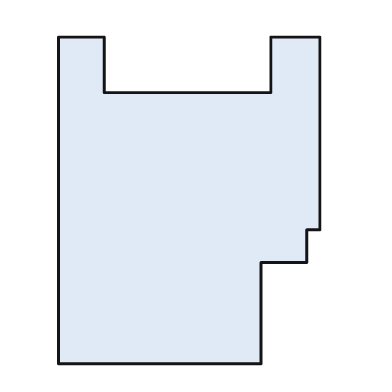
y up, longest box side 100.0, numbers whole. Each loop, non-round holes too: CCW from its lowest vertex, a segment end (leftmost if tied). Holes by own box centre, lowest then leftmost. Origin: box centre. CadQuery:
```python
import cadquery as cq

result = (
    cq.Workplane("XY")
    .moveTo(-40.0, -50.0)
    .lineTo(22.0, -50.0)
    .lineTo(22.0, -19.0)
    .lineTo(36.0, -19.0)
    .lineTo(36.0, -9.0)
    .lineTo(40.0, -9.0)
    .lineTo(40.0, 50.0)
    .lineTo(25.0, 50.0)
    .lineTo(25.0, 33.0)
    .lineTo(-26.0, 33.0)
    .lineTo(-26.0, 50.0)
    .lineTo(-40.0, 50.0)
    .close()
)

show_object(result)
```